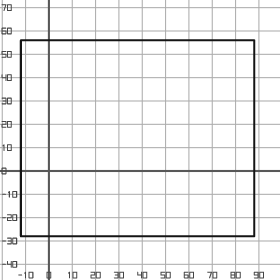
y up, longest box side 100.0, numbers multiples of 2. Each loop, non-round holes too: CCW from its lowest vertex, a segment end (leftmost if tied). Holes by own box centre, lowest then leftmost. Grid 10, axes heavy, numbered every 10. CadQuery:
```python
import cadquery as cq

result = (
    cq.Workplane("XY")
    .moveTo(-12.0, -28.0)
    .lineTo(88.0, -28.0)
    .lineTo(88.0, 56.0)
    .lineTo(-12.0, 56.0)
    .close()
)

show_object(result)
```